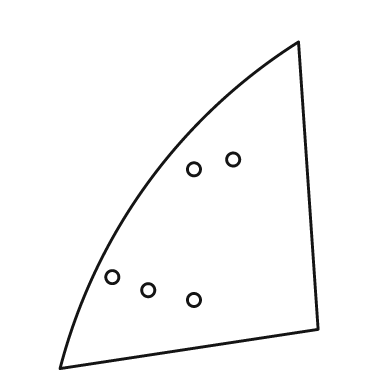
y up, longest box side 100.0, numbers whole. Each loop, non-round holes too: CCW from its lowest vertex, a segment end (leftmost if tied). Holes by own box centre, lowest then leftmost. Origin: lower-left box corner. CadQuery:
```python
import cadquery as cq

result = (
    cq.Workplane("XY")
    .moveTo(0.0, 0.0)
    .lineTo(79.0, 12.0)
    .lineTo(73.0, 100.0)
    .threePointArc((27.0, 57.0), (0.0, 0.0))
    .close()
    .moveTo(41.0, 21.0)
    .circle(2.0)
    .moveTo(27.0, 24.0)
    .circle(2.0)
    .moveTo(16.0, 28.0)
    .circle(2.0)
    .moveTo(41.0, 61.0)
    .circle(2.0)
    .moveTo(53.0, 64.0)
    .circle(2.0)
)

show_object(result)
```